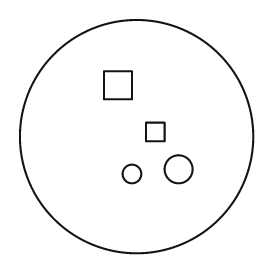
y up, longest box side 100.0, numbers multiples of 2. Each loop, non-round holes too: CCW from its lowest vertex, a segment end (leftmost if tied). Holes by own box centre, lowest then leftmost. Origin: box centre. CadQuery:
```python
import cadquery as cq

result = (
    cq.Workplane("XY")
    .moveTo(0.0, 0.0)
    .circle(50.0)
    .moveTo(-2.0, -16.0)
    .circle(4.0)
    .moveTo(18.0, -14.0)
    .circle(6.0)
    .moveTo(4.0, -2.0)
    .lineTo(12.0, -2.0)
    .lineTo(12.0, 6.0)
    .lineTo(4.0, 6.0)
    .close()
    .moveTo(-14.0, 16.0)
    .lineTo(-2.0, 16.0)
    .lineTo(-2.0, 28.0)
    .lineTo(-14.0, 28.0)
    .close()
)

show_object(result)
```